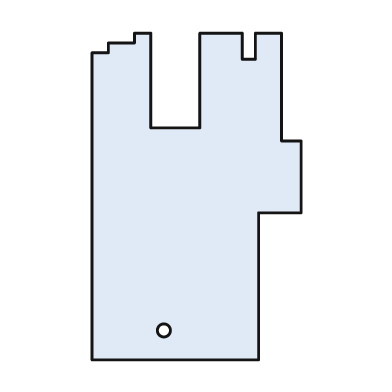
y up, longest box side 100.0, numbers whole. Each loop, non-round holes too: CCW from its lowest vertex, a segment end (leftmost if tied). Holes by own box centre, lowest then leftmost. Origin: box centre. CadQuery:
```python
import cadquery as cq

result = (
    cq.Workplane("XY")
    .moveTo(-32.0, -50.0)
    .lineTo(19.0, -50.0)
    .lineTo(19.0, -5.0)
    .lineTo(32.0, -5.0)
    .lineTo(32.0, 17.0)
    .lineTo(26.0, 17.0)
    .lineTo(26.0, 50.0)
    .lineTo(18.0, 50.0)
    .lineTo(18.0, 42.0)
    .lineTo(14.0, 42.0)
    .lineTo(14.0, 50.0)
    .lineTo(1.0, 50.0)
    .lineTo(1.0, 21.0)
    .lineTo(-14.0, 21.0)
    .lineTo(-14.0, 50.0)
    .lineTo(-19.0, 50.0)
    .lineTo(-19.0, 47.0)
    .lineTo(-27.0, 47.0)
    .lineTo(-27.0, 44.0)
    .lineTo(-32.0, 44.0)
    .close()
    .moveTo(-10.0, -41.0)
    .circle(2.0)
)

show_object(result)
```